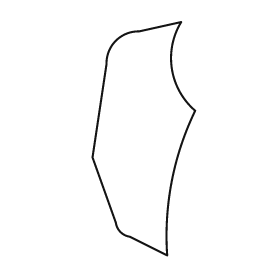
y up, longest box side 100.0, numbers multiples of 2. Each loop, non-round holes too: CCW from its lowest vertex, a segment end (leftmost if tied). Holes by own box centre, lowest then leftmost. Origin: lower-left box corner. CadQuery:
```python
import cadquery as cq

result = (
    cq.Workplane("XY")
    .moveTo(32.0, 0.0)
    .threePointArc((34.0, 32.0), (44.0, 62.0))
    .threePointArc((34.0, 80.0), (38.0, 100.0))
    .lineTo(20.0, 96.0)
    .threePointArc((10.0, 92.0), (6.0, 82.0))
    .lineTo(0.0, 42.0)
    .lineTo(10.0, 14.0)
    .threePointArc((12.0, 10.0), (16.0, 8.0))
    .close()
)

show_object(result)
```